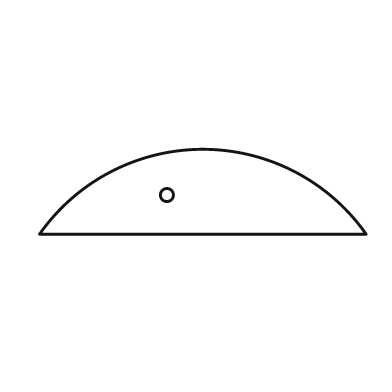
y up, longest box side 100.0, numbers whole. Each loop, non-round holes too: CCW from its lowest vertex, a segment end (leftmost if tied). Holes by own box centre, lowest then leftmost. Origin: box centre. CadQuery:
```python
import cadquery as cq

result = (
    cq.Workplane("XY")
    .moveTo(-50.0, -13.0)
    .lineTo(50.0, -13.0)
    .threePointArc((0.0, 13.0), (-50.0, -13.0))
    .close()
    .moveTo(-11.0, -1.0)
    .circle(2.0)
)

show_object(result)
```